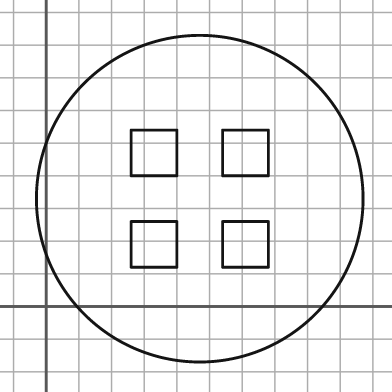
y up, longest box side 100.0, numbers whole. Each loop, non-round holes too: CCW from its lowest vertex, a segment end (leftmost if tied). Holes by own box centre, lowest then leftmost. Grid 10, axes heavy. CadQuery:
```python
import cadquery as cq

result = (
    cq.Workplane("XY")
    .moveTo(47.0, 33.0)
    .circle(50.0)
    .moveTo(26.0, 12.0)
    .lineTo(40.0, 12.0)
    .lineTo(40.0, 26.0)
    .lineTo(26.0, 26.0)
    .close()
    .moveTo(54.0, 12.0)
    .lineTo(68.0, 12.0)
    .lineTo(68.0, 26.0)
    .lineTo(54.0, 26.0)
    .close()
    .moveTo(26.0, 40.0)
    .lineTo(40.0, 40.0)
    .lineTo(40.0, 54.0)
    .lineTo(26.0, 54.0)
    .close()
    .moveTo(54.0, 40.0)
    .lineTo(68.0, 40.0)
    .lineTo(68.0, 54.0)
    .lineTo(54.0, 54.0)
    .close()
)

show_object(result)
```